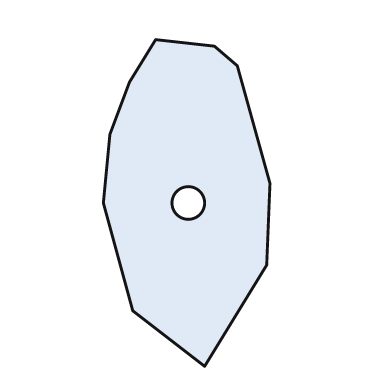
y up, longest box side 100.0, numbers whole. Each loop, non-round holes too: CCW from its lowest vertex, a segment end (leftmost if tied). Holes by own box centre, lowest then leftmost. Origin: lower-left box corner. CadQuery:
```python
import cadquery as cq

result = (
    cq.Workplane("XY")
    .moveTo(31.0, 0.0)
    .lineTo(50.0, 31.0)
    .lineTo(51.0, 56.0)
    .lineTo(41.0, 92.0)
    .lineTo(34.0, 98.0)
    .lineTo(16.0, 100.0)
    .lineTo(8.0, 87.0)
    .lineTo(2.0, 71.0)
    .lineTo(0.0, 50.0)
    .lineTo(9.0, 17.0)
    .close()
    .moveTo(26.0, 50.0)
    .circle(5.0)
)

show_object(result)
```